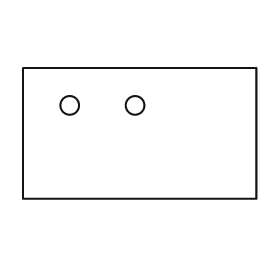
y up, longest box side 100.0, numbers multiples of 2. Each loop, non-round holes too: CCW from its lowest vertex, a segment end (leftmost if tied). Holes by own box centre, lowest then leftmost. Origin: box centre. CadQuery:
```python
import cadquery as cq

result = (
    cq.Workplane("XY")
    .moveTo(-50.0, -28.0)
    .lineTo(50.0, -28.0)
    .lineTo(50.0, 28.0)
    .lineTo(-50.0, 28.0)
    .close()
    .moveTo(-30.0, 12.0)
    .circle(4.0)
    .moveTo(-2.0, 12.0)
    .circle(4.0)
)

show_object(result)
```